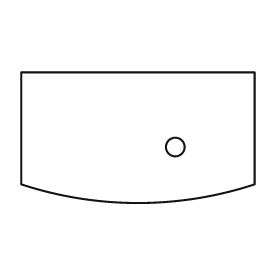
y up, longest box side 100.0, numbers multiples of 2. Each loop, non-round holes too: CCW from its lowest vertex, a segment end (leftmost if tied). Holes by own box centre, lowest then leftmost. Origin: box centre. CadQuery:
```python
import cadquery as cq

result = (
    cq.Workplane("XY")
    .moveTo(-50.0, -20.0)
    .threePointArc((0.0, -28.0), (50.0, -20.0))
    .lineTo(50.0, 28.0)
    .lineTo(-50.0, 28.0)
    .close()
    .moveTo(16.0, -4.0)
    .circle(4.0)
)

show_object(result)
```